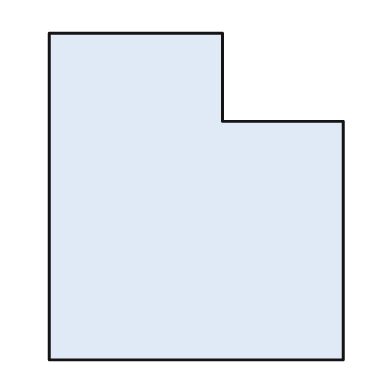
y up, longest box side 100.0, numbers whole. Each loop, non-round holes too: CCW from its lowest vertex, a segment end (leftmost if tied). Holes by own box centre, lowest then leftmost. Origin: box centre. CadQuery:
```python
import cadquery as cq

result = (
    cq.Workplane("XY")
    .moveTo(-45.0, -50.0)
    .lineTo(45.0, -50.0)
    .lineTo(45.0, 23.0)
    .lineTo(8.0, 23.0)
    .lineTo(8.0, 50.0)
    .lineTo(-45.0, 50.0)
    .close()
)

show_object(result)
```